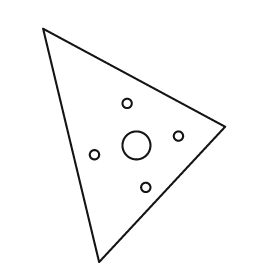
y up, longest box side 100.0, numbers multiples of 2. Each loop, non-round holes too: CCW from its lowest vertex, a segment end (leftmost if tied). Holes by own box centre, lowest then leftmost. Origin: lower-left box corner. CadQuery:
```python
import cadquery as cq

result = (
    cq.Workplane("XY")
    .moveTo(24.0, 0.0)
    .lineTo(78.0, 58.0)
    .lineTo(0.0, 100.0)
    .close()
    .moveTo(44.0, 32.0)
    .circle(2.0)
    .moveTo(22.0, 46.0)
    .circle(2.0)
    .moveTo(40.0, 50.0)
    .circle(6.0)
    .moveTo(58.0, 54.0)
    .circle(2.0)
    .moveTo(36.0, 68.0)
    .circle(2.0)
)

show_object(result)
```